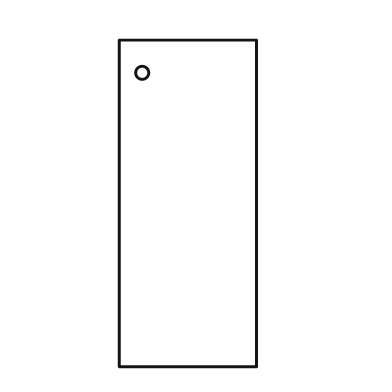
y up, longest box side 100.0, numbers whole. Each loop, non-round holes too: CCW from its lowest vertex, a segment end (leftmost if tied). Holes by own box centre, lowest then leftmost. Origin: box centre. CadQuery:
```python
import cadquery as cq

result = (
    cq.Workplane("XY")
    .moveTo(-21.0, -50.0)
    .lineTo(21.0, -50.0)
    .lineTo(21.0, 50.0)
    .lineTo(-21.0, 50.0)
    .close()
    .moveTo(-14.0, 40.0)
    .circle(2.0)
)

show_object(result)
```